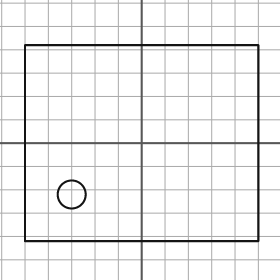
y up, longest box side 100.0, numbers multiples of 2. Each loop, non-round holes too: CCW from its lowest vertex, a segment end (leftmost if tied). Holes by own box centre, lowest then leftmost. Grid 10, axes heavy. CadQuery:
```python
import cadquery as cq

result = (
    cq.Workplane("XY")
    .moveTo(-50.0, -42.0)
    .lineTo(50.0, -42.0)
    .lineTo(50.0, 42.0)
    .lineTo(-50.0, 42.0)
    .close()
    .moveTo(-30.0, -22.0)
    .circle(6.0)
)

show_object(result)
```